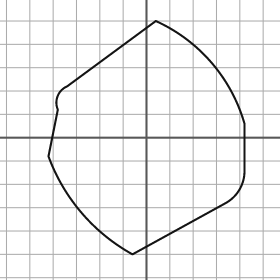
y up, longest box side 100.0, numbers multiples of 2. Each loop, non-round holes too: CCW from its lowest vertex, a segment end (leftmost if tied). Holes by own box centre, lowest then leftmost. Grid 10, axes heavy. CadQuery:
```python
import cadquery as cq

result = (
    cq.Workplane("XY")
    .moveTo(-6.0, -50.0)
    .lineTo(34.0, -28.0)
    .threePointArc((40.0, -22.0), (42.0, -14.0))
    .lineTo(42.0, 6.0)
    .threePointArc((28.0, 32.0), (4.0, 50.0))
    .lineTo(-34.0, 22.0)
    .threePointArc((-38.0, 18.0), (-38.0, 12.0))
    .lineTo(-42.0, -8.0)
    .threePointArc((-28.0, -32.0), (-6.0, -50.0))
    .close()
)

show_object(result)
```